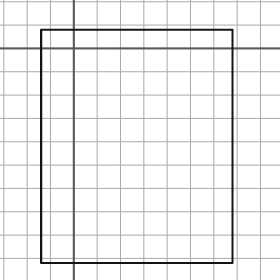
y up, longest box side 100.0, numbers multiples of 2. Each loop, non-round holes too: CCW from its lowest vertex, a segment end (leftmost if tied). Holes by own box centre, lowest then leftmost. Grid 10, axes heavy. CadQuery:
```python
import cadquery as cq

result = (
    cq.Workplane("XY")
    .moveTo(-14.0, -92.0)
    .lineTo(68.0, -92.0)
    .lineTo(68.0, 8.0)
    .lineTo(-14.0, 8.0)
    .close()
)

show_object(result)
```